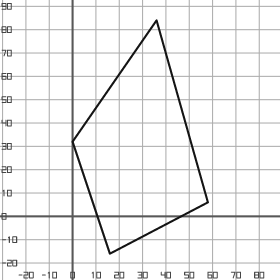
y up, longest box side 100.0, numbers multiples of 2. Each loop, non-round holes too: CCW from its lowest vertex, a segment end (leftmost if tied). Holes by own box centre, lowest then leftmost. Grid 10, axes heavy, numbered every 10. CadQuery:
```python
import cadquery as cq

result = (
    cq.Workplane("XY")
    .moveTo(16.0, -16.0)
    .lineTo(58.0, 6.0)
    .lineTo(36.0, 84.0)
    .lineTo(0.0, 32.0)
    .close()
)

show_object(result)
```